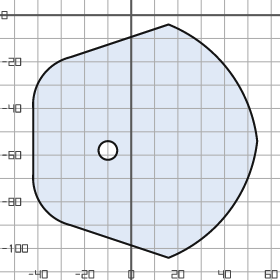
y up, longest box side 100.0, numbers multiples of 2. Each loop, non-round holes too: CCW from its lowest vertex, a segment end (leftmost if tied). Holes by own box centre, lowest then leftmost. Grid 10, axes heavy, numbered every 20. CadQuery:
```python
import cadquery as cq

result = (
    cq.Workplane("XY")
    .moveTo(16.0, -104.0)
    .threePointArc((42.0, -84.0), (54.0, -54.0))
    .threePointArc((42.0, -24.0), (16.0, -4.0))
    .lineTo(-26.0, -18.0)
    .threePointArc((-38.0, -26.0), (-42.0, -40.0))
    .lineTo(-42.0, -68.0)
    .threePointArc((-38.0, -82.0), (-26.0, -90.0))
    .close()
    .moveTo(-10.0, -58.0)
    .circle(4.0)
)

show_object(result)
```